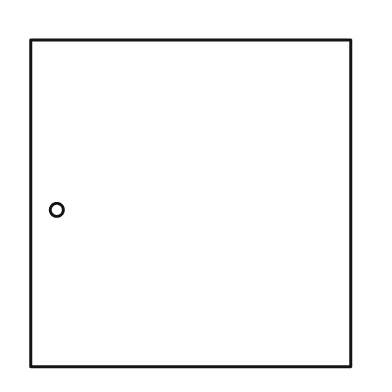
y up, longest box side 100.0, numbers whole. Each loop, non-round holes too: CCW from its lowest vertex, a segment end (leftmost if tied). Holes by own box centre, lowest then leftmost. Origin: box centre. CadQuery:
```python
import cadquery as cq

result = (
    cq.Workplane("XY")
    .moveTo(-49.0, -50.0)
    .lineTo(49.0, -50.0)
    .lineTo(49.0, 50.0)
    .lineTo(-49.0, 50.0)
    .close()
    .moveTo(-41.0, -2.0)
    .circle(2.0)
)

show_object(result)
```